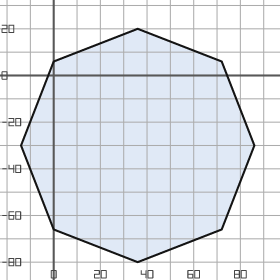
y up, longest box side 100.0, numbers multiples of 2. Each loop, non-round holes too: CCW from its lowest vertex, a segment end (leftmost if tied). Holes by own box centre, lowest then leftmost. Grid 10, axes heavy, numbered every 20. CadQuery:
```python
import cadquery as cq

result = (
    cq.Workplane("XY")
    .moveTo(36.0, -80.0)
    .lineTo(72.0, -66.0)
    .lineTo(86.0, -30.0)
    .lineTo(72.0, 6.0)
    .lineTo(36.0, 20.0)
    .lineTo(0.0, 6.0)
    .lineTo(-14.0, -30.0)
    .lineTo(0.0, -66.0)
    .close()
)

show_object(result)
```